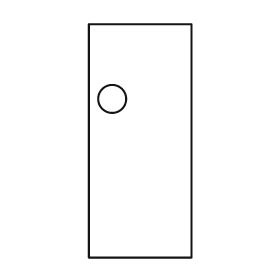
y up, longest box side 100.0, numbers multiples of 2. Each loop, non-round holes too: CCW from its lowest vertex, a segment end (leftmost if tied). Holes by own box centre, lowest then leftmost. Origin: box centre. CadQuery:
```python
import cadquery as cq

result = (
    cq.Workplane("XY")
    .moveTo(-22.0, -50.0)
    .lineTo(22.0, -50.0)
    .lineTo(22.0, 50.0)
    .lineTo(-22.0, 50.0)
    .close()
    .moveTo(-12.0, 18.0)
    .circle(6.0)
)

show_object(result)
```